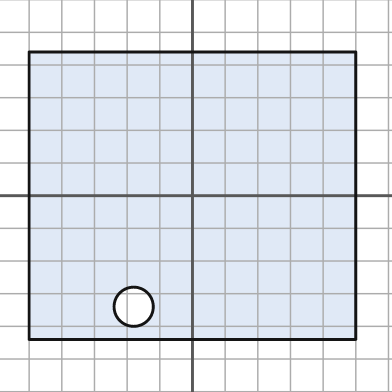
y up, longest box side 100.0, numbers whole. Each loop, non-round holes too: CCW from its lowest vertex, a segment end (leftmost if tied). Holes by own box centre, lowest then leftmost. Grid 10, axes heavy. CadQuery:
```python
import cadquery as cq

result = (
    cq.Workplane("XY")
    .moveTo(-50.0, -44.0)
    .lineTo(50.0, -44.0)
    .lineTo(50.0, 44.0)
    .lineTo(-50.0, 44.0)
    .close()
    .moveTo(-18.0, -34.0)
    .circle(6.0)
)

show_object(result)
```